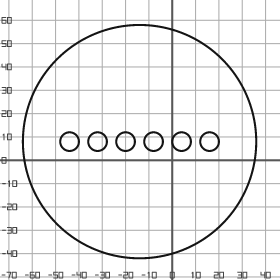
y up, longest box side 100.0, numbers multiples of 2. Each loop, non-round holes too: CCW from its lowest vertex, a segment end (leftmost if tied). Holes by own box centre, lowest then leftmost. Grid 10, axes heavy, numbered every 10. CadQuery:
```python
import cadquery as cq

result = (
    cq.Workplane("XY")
    .moveTo(-14.0, 8.0)
    .circle(50.0)
    .moveTo(-44.0, 8.0)
    .circle(4.0)
    .moveTo(-32.0, 8.0)
    .circle(4.0)
    .moveTo(-20.0, 8.0)
    .circle(4.0)
    .moveTo(-8.0, 8.0)
    .circle(4.0)
    .moveTo(4.0, 8.0)
    .circle(4.0)
    .moveTo(16.0, 8.0)
    .circle(4.0)
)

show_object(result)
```